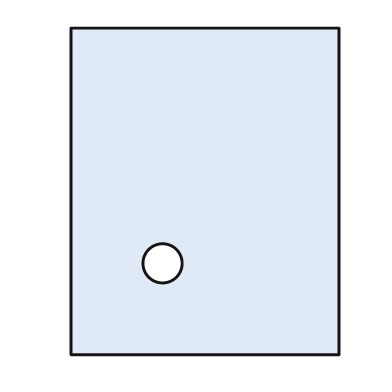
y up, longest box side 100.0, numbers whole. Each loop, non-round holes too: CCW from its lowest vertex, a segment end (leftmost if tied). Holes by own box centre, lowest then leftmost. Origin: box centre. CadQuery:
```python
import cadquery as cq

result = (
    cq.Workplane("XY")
    .moveTo(-41.0, -50.0)
    .lineTo(41.0, -50.0)
    .lineTo(41.0, 50.0)
    .lineTo(-41.0, 50.0)
    .close()
    .moveTo(-13.0, -22.0)
    .circle(6.0)
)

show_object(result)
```